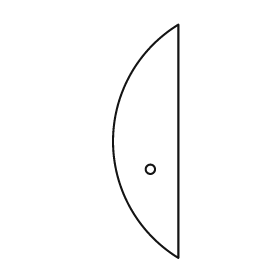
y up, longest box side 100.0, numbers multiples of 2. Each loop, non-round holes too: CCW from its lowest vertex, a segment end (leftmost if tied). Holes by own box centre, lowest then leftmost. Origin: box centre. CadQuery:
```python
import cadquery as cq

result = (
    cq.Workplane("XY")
    .moveTo(14.0, -50.0)
    .lineTo(14.0, 50.0)
    .threePointArc((-14.0, 0.0), (14.0, -50.0))
    .close()
    .moveTo(2.0, -12.0)
    .circle(2.0)
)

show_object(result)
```